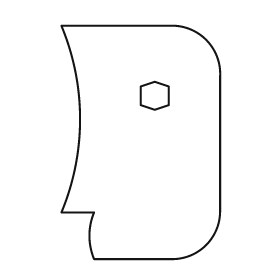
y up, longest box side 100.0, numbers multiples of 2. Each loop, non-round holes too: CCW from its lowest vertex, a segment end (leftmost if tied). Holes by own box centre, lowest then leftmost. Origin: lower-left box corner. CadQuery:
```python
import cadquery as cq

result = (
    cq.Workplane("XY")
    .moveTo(14.0, 0.0)
    .lineTo(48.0, 0.0)
    .threePointArc((62.0, 6.0), (68.0, 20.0))
    .lineTo(68.0, 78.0)
    .threePointArc((62.0, 94.0), (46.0, 100.0))
    .lineTo(0.0, 100.0)
    .threePointArc((8.0, 60.0), (0.0, 20.0))
    .lineTo(14.0, 20.0)
    .threePointArc((12.0, 10.0), (14.0, 0.0))
    .close()
    .moveTo(40.0, 64.0)
    .lineTo(46.0, 66.0)
    .lineTo(46.0, 74.0)
    .lineTo(40.0, 76.0)
    .lineTo(34.0, 74.0)
    .lineTo(34.0, 66.0)
    .close()
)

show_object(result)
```